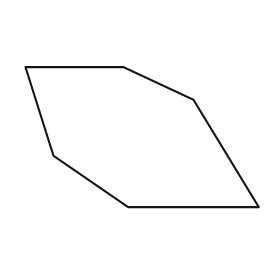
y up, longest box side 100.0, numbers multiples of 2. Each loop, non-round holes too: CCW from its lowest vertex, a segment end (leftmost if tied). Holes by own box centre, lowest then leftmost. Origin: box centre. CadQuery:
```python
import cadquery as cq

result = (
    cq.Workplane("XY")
    .moveTo(-6.0, -30.0)
    .lineTo(50.0, -30.0)
    .lineTo(22.0, 16.0)
    .lineTo(-8.0, 30.0)
    .lineTo(-50.0, 30.0)
    .lineTo(-38.0, -8.0)
    .close()
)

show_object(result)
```